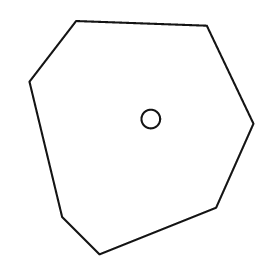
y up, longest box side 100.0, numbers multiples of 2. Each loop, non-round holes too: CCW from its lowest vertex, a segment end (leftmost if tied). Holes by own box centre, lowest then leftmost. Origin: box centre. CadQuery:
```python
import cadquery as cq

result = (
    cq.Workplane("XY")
    .moveTo(-18.0, -50.0)
    .lineTo(32.0, -30.0)
    .lineTo(48.0, 6.0)
    .lineTo(28.0, 48.0)
    .lineTo(-28.0, 50.0)
    .lineTo(-48.0, 24.0)
    .lineTo(-34.0, -34.0)
    .close()
    .moveTo(4.0, 8.0)
    .circle(4.0)
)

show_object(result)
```